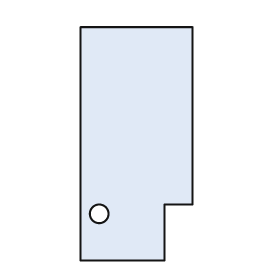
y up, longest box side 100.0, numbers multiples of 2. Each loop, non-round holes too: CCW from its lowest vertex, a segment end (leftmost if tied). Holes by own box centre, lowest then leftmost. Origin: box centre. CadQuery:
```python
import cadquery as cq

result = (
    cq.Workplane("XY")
    .moveTo(-24.0, -50.0)
    .lineTo(12.0, -50.0)
    .lineTo(12.0, -26.0)
    .lineTo(24.0, -26.0)
    .lineTo(24.0, 50.0)
    .lineTo(-24.0, 50.0)
    .close()
    .moveTo(-16.0, -30.0)
    .circle(4.0)
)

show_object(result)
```